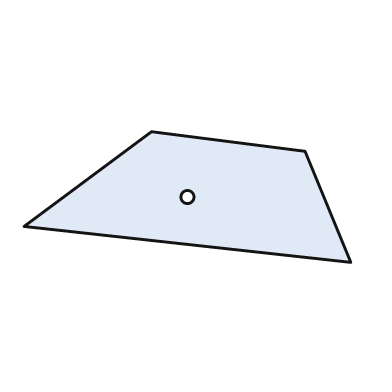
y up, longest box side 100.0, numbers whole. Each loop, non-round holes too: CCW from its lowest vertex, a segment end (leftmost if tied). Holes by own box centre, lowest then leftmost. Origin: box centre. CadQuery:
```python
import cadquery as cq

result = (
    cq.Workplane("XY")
    .moveTo(50.0, -20.0)
    .lineTo(36.0, 14.0)
    .lineTo(-11.0, 20.0)
    .lineTo(-50.0, -9.0)
    .close()
    .moveTo(0.0, 0.0)
    .circle(2.0)
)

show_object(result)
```